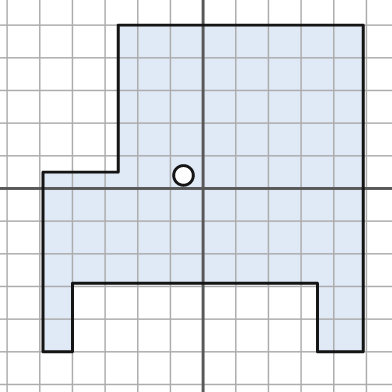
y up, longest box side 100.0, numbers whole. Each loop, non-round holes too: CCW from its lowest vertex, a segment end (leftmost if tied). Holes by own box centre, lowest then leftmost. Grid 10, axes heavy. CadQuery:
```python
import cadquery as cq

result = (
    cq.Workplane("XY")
    .moveTo(-49.0, -50.0)
    .lineTo(-40.0, -50.0)
    .lineTo(-40.0, -29.0)
    .lineTo(35.0, -29.0)
    .lineTo(35.0, -50.0)
    .lineTo(49.0, -50.0)
    .lineTo(49.0, 50.0)
    .lineTo(-26.0, 50.0)
    .lineTo(-26.0, 5.0)
    .lineTo(-49.0, 5.0)
    .close()
    .moveTo(-6.0, 4.0)
    .circle(3.0)
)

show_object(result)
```